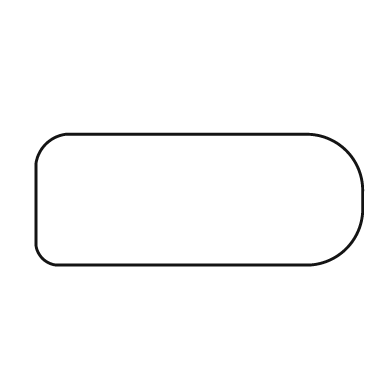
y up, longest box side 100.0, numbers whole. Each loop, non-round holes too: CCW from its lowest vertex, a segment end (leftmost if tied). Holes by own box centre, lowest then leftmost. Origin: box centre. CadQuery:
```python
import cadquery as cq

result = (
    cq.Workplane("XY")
    .moveTo(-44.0, -20.0)
    .lineTo(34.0, -20.0)
    .threePointArc((45.0, -15.0), (50.0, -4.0))
    .lineTo(50.0, 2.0)
    .threePointArc((45.0, 15.0), (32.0, 20.0))
    .lineTo(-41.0, 20.0)
    .threePointArc((-47.0, 17.0), (-50.0, 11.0))
    .lineTo(-50.0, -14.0)
    .threePointArc((-48.0, -18.0), (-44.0, -20.0))
    .close()
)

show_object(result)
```